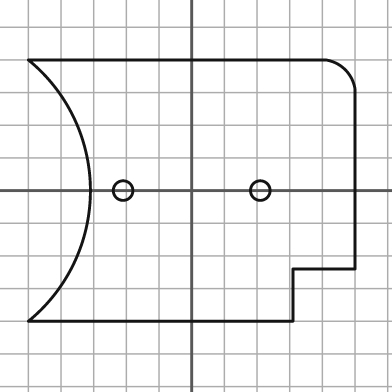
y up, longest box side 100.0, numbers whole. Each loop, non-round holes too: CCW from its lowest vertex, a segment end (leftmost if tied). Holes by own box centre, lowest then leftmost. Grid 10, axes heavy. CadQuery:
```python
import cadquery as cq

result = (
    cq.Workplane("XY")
    .moveTo(-50.0, -40.0)
    .lineTo(31.0, -40.0)
    .lineTo(31.0, -24.0)
    .lineTo(50.0, -24.0)
    .lineTo(50.0, 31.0)
    .threePointArc((47.0, 37.0), (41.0, 40.0))
    .lineTo(-50.0, 40.0)
    .threePointArc((-31.0, 0.0), (-50.0, -40.0))
    .close()
    .moveTo(-21.0, 0.0)
    .circle(3.0)
    .moveTo(21.0, 0.0)
    .circle(3.0)
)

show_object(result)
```